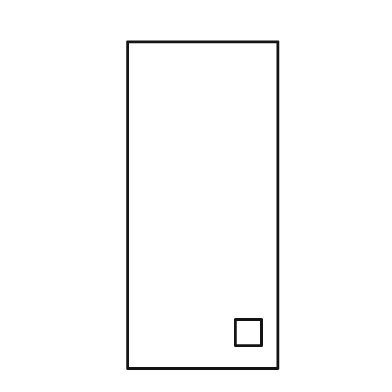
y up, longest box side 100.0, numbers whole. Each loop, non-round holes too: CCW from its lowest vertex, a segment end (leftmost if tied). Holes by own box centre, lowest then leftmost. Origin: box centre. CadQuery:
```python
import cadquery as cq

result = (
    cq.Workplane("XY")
    .moveTo(-23.0, -50.0)
    .lineTo(23.0, -50.0)
    .lineTo(23.0, 50.0)
    .lineTo(-23.0, 50.0)
    .close()
    .moveTo(10.0, -43.0)
    .lineTo(18.0, -43.0)
    .lineTo(18.0, -35.0)
    .lineTo(10.0, -35.0)
    .close()
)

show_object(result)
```